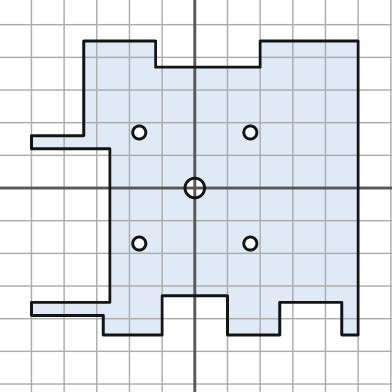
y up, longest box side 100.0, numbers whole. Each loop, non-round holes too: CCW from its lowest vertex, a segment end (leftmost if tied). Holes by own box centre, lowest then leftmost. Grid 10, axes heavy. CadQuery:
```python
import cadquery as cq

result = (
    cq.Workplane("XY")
    .moveTo(-28.0, -45.0)
    .lineTo(-10.0, -45.0)
    .lineTo(-10.0, -33.0)
    .lineTo(10.0, -33.0)
    .lineTo(10.0, -45.0)
    .lineTo(26.0, -45.0)
    .lineTo(26.0, -35.0)
    .lineTo(45.0, -35.0)
    .lineTo(45.0, -45.0)
    .lineTo(50.0, -45.0)
    .lineTo(50.0, 45.0)
    .lineTo(20.0, 45.0)
    .lineTo(20.0, 37.0)
    .lineTo(-12.0, 37.0)
    .lineTo(-12.0, 45.0)
    .lineTo(-34.0, 45.0)
    .lineTo(-34.0, 16.0)
    .lineTo(-50.0, 16.0)
    .lineTo(-50.0, 12.0)
    .lineTo(-26.0, 12.0)
    .lineTo(-26.0, -35.0)
    .lineTo(-50.0, -35.0)
    .lineTo(-50.0, -39.0)
    .lineTo(-28.0, -39.0)
    .close()
    .moveTo(-17.0, -17.0)
    .circle(2.0)
    .moveTo(17.0, -17.0)
    .circle(2.0)
    .moveTo(0.0, 0.0)
    .circle(3.0)
    .moveTo(-17.0, 17.0)
    .circle(2.0)
    .moveTo(17.0, 17.0)
    .circle(2.0)
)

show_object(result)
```